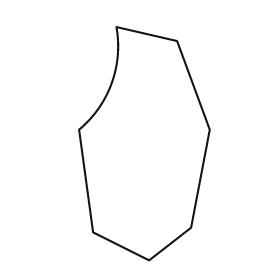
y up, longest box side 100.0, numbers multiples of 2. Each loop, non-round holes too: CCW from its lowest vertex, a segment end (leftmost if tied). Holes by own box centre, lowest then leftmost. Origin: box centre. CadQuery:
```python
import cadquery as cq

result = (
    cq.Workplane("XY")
    .moveTo(2.0, -50.0)
    .lineTo(20.0, -36.0)
    .lineTo(28.0, 6.0)
    .lineTo(14.0, 44.0)
    .lineTo(-12.0, 50.0)
    .threePointArc((-14.0, 26.0), (-28.0, 6.0))
    .lineTo(-22.0, -38.0)
    .close()
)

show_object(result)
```